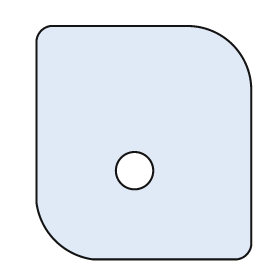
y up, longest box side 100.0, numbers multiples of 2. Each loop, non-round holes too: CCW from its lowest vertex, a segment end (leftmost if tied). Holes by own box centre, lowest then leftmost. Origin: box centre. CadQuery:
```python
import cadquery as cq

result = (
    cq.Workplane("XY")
    .moveTo(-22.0, -50.0)
    .lineTo(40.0, -50.0)
    .threePointArc((44.0, -48.0), (46.0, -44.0))
    .lineTo(46.0, 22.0)
    .threePointArc((38.0, 42.0), (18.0, 50.0))
    .lineTo(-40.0, 50.0)
    .threePointArc((-44.0, 48.0), (-46.0, 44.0))
    .lineTo(-46.0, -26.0)
    .threePointArc((-38.0, -42.0), (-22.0, -50.0))
    .close()
    .moveTo(-4.0, -12.0)
    .circle(8.0)
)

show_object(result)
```